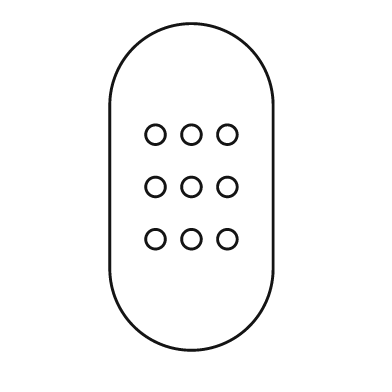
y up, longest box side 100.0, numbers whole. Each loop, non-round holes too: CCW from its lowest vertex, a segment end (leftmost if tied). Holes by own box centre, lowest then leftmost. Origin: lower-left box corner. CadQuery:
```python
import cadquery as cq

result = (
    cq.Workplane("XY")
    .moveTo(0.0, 25.0)
    .threePointArc((25.0, 0.0), (50.0, 25.0))
    .lineTo(50.0, 75.0)
    .threePointArc((25.0, 100.0), (0.0, 75.0))
    .close()
    .moveTo(14.0, 34.0)
    .circle(3.0)
    .moveTo(25.0, 34.0)
    .circle(3.0)
    .moveTo(36.0, 34.0)
    .circle(3.0)
    .moveTo(14.0, 50.0)
    .circle(3.0)
    .moveTo(25.0, 50.0)
    .circle(3.0)
    .moveTo(36.0, 50.0)
    .circle(3.0)
    .moveTo(14.0, 66.0)
    .circle(3.0)
    .moveTo(25.0, 66.0)
    .circle(3.0)
    .moveTo(36.0, 66.0)
    .circle(3.0)
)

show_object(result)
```